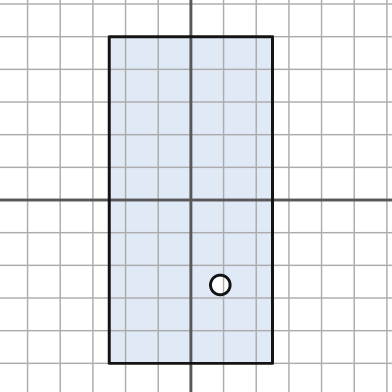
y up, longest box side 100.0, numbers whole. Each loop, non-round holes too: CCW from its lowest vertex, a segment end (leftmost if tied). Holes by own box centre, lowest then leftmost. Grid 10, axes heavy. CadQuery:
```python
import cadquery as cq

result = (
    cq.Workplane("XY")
    .moveTo(-25.0, -50.0)
    .lineTo(25.0, -50.0)
    .lineTo(25.0, 50.0)
    .lineTo(-25.0, 50.0)
    .close()
    .moveTo(9.0, -26.0)
    .circle(3.0)
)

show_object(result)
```